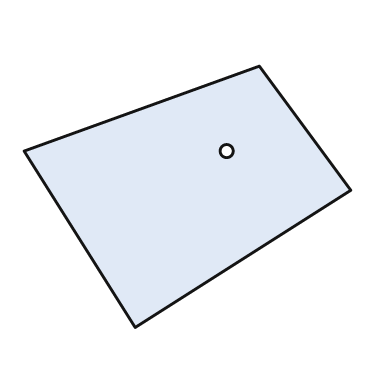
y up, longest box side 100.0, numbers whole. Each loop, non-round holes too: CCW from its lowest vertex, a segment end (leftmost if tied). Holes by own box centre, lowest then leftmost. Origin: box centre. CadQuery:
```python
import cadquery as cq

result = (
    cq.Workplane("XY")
    .moveTo(-16.0, -40.0)
    .lineTo(50.0, 2.0)
    .lineTo(22.0, 40.0)
    .lineTo(-50.0, 14.0)
    .close()
    .moveTo(12.0, 14.0)
    .circle(2.0)
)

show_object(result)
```